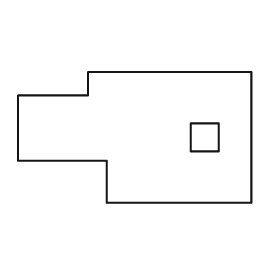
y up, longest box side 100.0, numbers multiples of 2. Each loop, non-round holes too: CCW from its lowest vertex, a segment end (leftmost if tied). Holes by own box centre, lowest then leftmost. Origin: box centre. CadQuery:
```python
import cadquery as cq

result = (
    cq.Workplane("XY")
    .moveTo(-12.0, -28.0)
    .lineTo(50.0, -28.0)
    .lineTo(50.0, 28.0)
    .lineTo(-20.0, 28.0)
    .lineTo(-20.0, 18.0)
    .lineTo(-50.0, 18.0)
    .lineTo(-50.0, -10.0)
    .lineTo(-12.0, -10.0)
    .close()
    .moveTo(24.0, -6.0)
    .lineTo(36.0, -6.0)
    .lineTo(36.0, 6.0)
    .lineTo(24.0, 6.0)
    .close()
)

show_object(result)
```